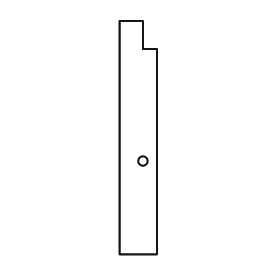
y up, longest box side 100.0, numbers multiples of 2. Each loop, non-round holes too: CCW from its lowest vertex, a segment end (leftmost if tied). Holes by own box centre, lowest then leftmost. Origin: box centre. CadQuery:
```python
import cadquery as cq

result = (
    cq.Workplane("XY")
    .moveTo(-8.0, -50.0)
    .lineTo(8.0, -50.0)
    .lineTo(8.0, 38.0)
    .lineTo(2.0, 38.0)
    .lineTo(2.0, 50.0)
    .lineTo(-8.0, 50.0)
    .close()
    .moveTo(2.0, -10.0)
    .circle(2.0)
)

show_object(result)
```